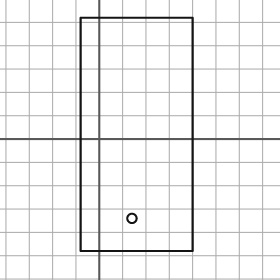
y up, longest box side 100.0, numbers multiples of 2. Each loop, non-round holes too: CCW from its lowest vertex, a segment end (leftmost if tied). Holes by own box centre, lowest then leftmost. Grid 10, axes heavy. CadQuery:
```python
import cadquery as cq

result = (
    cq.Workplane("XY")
    .moveTo(-8.0, -48.0)
    .lineTo(40.0, -48.0)
    .lineTo(40.0, 52.0)
    .lineTo(-8.0, 52.0)
    .close()
    .moveTo(14.0, -34.0)
    .circle(2.0)
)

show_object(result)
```